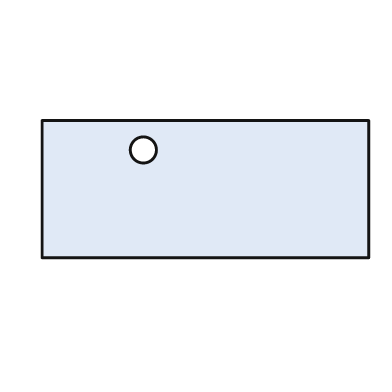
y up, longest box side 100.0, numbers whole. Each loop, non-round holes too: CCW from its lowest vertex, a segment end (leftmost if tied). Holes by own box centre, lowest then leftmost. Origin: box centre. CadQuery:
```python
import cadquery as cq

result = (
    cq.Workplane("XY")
    .moveTo(-50.0, -21.0)
    .lineTo(50.0, -21.0)
    .lineTo(50.0, 21.0)
    .lineTo(-50.0, 21.0)
    .close()
    .moveTo(-19.0, 12.0)
    .circle(4.0)
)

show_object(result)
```